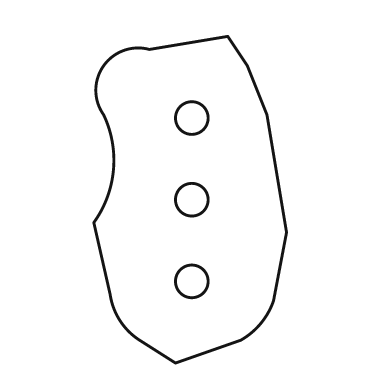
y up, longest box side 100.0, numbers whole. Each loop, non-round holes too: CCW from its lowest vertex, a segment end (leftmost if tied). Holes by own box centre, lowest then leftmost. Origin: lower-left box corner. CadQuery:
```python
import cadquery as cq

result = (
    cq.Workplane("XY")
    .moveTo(25.0, 0.0)
    .lineTo(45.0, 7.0)
    .threePointArc((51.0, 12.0), (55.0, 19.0))
    .lineTo(59.0, 40.0)
    .lineTo(53.0, 76.0)
    .lineTo(47.0, 91.0)
    .lineTo(41.0, 100.0)
    .lineTo(17.0, 96.0)
    .threePointArc((3.0, 91.0), (3.0, 76.0))
    .threePointArc((6.0, 59.0), (0.0, 43.0))
    .lineTo(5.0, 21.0)
    .threePointArc((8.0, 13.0), (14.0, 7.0))
    .close()
    .moveTo(30.0, 25.0)
    .circle(5.0)
    .moveTo(30.0, 50.0)
    .circle(5.0)
    .moveTo(30.0, 75.0)
    .circle(5.0)
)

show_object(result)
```